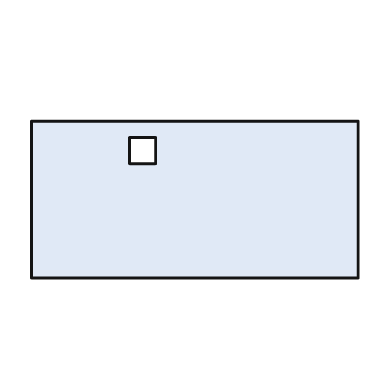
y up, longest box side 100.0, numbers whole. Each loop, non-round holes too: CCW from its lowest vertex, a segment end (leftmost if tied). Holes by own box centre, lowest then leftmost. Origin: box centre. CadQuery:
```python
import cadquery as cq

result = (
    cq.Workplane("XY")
    .moveTo(-50.0, -24.0)
    .lineTo(50.0, -24.0)
    .lineTo(50.0, 24.0)
    .lineTo(-50.0, 24.0)
    .close()
    .moveTo(-20.0, 11.0)
    .lineTo(-12.0, 11.0)
    .lineTo(-12.0, 19.0)
    .lineTo(-20.0, 19.0)
    .close()
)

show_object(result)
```